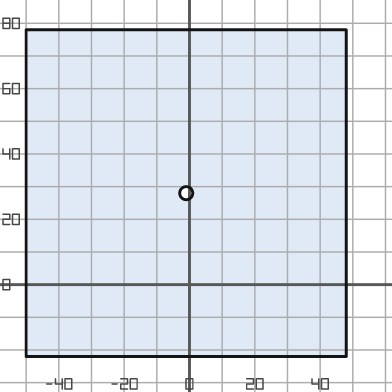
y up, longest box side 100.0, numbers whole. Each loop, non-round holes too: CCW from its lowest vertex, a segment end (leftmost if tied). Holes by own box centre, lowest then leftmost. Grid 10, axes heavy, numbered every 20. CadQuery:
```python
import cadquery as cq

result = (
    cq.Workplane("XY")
    .moveTo(-50.0, -22.0)
    .lineTo(48.0, -22.0)
    .lineTo(48.0, 78.0)
    .lineTo(-50.0, 78.0)
    .close()
    .moveTo(-1.0, 28.0)
    .circle(2.0)
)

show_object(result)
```